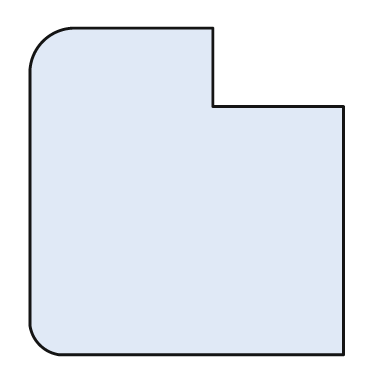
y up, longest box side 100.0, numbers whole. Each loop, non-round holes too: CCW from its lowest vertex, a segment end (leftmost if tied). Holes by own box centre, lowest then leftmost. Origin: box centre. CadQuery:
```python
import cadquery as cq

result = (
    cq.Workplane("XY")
    .moveTo(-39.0, -50.0)
    .lineTo(48.0, -50.0)
    .lineTo(48.0, 26.0)
    .lineTo(8.0, 26.0)
    .lineTo(8.0, 50.0)
    .lineTo(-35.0, 50.0)
    .threePointArc((-44.0, 46.0), (-48.0, 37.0))
    .lineTo(-48.0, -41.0)
    .threePointArc((-45.0, -47.0), (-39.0, -50.0))
    .close()
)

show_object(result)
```